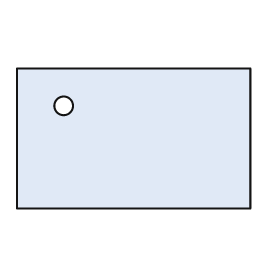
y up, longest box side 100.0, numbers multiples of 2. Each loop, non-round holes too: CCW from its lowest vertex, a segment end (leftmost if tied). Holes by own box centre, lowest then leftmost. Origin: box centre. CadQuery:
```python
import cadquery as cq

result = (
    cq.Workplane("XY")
    .moveTo(-50.0, -30.0)
    .lineTo(50.0, -30.0)
    .lineTo(50.0, 30.0)
    .lineTo(-50.0, 30.0)
    .close()
    .moveTo(-30.0, 14.0)
    .circle(4.0)
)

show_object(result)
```